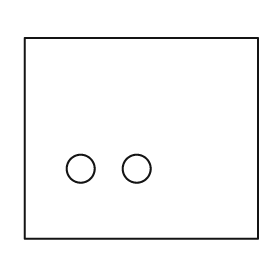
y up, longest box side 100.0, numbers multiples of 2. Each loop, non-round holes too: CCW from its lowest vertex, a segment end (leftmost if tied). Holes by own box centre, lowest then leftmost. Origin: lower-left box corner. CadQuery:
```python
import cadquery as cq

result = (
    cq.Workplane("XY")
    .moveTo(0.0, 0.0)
    .lineTo(100.0, 0.0)
    .lineTo(100.0, 86.0)
    .lineTo(0.0, 86.0)
    .close()
    .moveTo(24.0, 30.0)
    .circle(6.0)
    .moveTo(48.0, 30.0)
    .circle(6.0)
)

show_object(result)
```